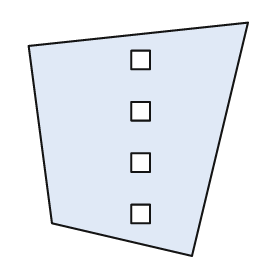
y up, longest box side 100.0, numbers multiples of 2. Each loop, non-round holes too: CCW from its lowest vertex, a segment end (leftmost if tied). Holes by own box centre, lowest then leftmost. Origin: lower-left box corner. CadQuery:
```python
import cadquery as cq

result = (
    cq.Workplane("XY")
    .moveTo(70.0, 0.0)
    .lineTo(94.0, 100.0)
    .lineTo(0.0, 90.0)
    .lineTo(10.0, 14.0)
    .close()
    .moveTo(44.0, 14.0)
    .lineTo(52.0, 14.0)
    .lineTo(52.0, 22.0)
    .lineTo(44.0, 22.0)
    .close()
    .moveTo(44.0, 36.0)
    .lineTo(52.0, 36.0)
    .lineTo(52.0, 44.0)
    .lineTo(44.0, 44.0)
    .close()
    .moveTo(44.0, 58.0)
    .lineTo(52.0, 58.0)
    .lineTo(52.0, 66.0)
    .lineTo(44.0, 66.0)
    .close()
    .moveTo(44.0, 80.0)
    .lineTo(52.0, 80.0)
    .lineTo(52.0, 88.0)
    .lineTo(44.0, 88.0)
    .close()
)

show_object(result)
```